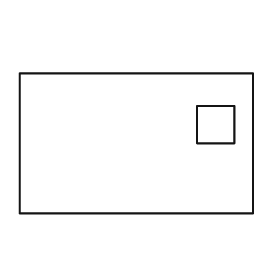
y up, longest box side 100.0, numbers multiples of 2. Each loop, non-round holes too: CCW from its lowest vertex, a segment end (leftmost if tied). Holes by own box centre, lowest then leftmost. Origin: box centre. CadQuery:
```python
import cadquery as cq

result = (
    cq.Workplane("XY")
    .moveTo(-50.0, -30.0)
    .lineTo(50.0, -30.0)
    .lineTo(50.0, 30.0)
    .lineTo(-50.0, 30.0)
    .close()
    .moveTo(26.0, 0.0)
    .lineTo(42.0, 0.0)
    .lineTo(42.0, 16.0)
    .lineTo(26.0, 16.0)
    .close()
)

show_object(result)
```